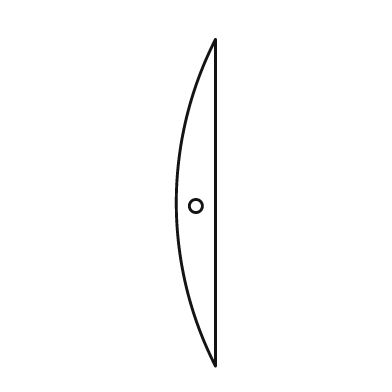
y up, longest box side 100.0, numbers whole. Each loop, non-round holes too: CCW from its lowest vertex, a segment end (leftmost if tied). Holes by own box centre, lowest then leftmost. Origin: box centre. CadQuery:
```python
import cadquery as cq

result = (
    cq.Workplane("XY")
    .moveTo(6.0, -50.0)
    .lineTo(6.0, 50.0)
    .threePointArc((-6.0, 0.0), (6.0, -50.0))
    .close()
    .moveTo(0.0, -1.0)
    .circle(2.0)
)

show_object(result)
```